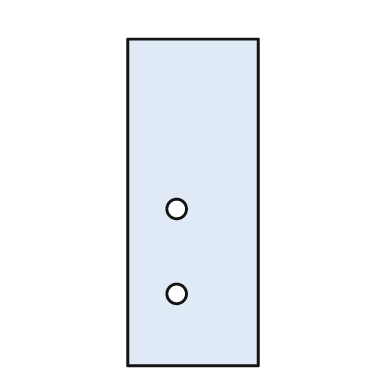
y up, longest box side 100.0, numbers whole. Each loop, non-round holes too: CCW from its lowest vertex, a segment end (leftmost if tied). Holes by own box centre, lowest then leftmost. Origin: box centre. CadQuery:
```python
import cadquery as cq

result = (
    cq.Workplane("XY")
    .moveTo(-20.0, -50.0)
    .lineTo(20.0, -50.0)
    .lineTo(20.0, 50.0)
    .lineTo(-20.0, 50.0)
    .close()
    .moveTo(-5.0, -28.0)
    .circle(3.0)
    .moveTo(-5.0, -2.0)
    .circle(3.0)
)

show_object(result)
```